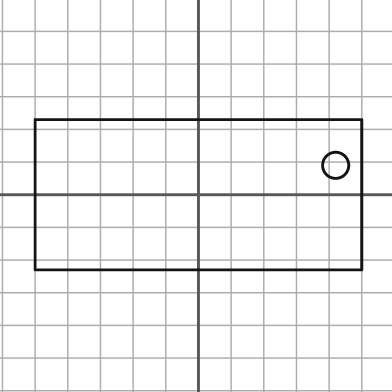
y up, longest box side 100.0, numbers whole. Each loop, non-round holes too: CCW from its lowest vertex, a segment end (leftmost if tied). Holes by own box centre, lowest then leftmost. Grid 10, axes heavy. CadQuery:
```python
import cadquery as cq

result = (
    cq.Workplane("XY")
    .moveTo(-50.0, -23.0)
    .lineTo(50.0, -23.0)
    .lineTo(50.0, 23.0)
    .lineTo(-50.0, 23.0)
    .close()
    .moveTo(42.0, 9.0)
    .circle(4.0)
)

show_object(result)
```